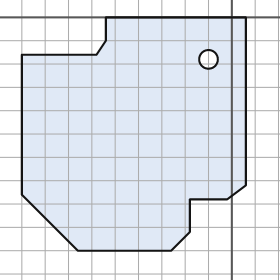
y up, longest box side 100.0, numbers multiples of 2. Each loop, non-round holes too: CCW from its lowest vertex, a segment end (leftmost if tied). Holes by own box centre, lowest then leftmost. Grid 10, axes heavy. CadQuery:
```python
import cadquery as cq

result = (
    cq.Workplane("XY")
    .moveTo(-66.0, -100.0)
    .lineTo(-26.0, -100.0)
    .lineTo(-18.0, -92.0)
    .lineTo(-18.0, -78.0)
    .lineTo(-2.0, -78.0)
    .lineTo(6.0, -72.0)
    .lineTo(6.0, 0.0)
    .lineTo(-54.0, 0.0)
    .lineTo(-54.0, -10.0)
    .lineTo(-58.0, -16.0)
    .lineTo(-90.0, -16.0)
    .lineTo(-90.0, -76.0)
    .close()
    .moveTo(-10.0, -18.0)
    .circle(4.0)
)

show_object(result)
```